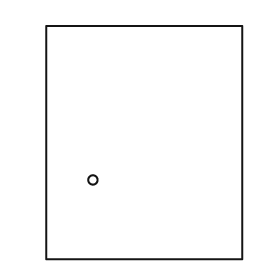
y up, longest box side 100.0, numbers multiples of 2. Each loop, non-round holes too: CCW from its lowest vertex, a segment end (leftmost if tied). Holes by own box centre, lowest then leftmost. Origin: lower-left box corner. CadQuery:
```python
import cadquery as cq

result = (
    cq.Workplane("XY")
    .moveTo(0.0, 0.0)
    .lineTo(84.0, 0.0)
    .lineTo(84.0, 100.0)
    .lineTo(0.0, 100.0)
    .close()
    .moveTo(20.0, 34.0)
    .circle(2.0)
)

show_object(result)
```